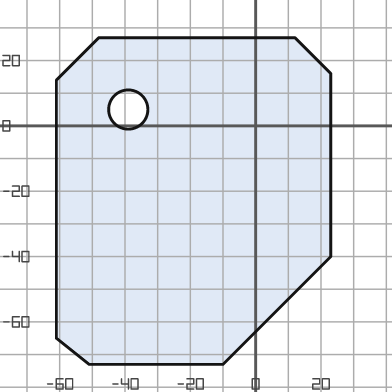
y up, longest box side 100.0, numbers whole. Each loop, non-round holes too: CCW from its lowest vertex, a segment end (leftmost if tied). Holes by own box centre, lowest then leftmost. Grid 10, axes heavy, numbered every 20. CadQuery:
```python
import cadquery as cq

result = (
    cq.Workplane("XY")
    .moveTo(-51.0, -73.0)
    .lineTo(-10.0, -73.0)
    .lineTo(23.0, -40.0)
    .lineTo(23.0, 16.0)
    .lineTo(12.0, 27.0)
    .lineTo(-48.0, 27.0)
    .lineTo(-61.0, 14.0)
    .lineTo(-61.0, -65.0)
    .close()
    .moveTo(-39.0, 5.0)
    .circle(6.0)
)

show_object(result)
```